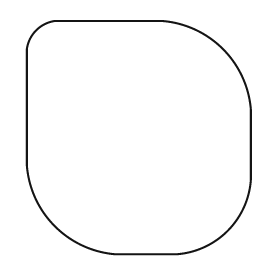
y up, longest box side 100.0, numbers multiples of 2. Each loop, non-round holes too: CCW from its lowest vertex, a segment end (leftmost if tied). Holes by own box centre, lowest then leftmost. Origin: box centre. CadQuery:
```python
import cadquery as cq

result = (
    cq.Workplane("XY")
    .moveTo(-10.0, -50.0)
    .lineTo(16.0, -50.0)
    .threePointArc((38.0, -40.0), (48.0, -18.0))
    .lineTo(48.0, 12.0)
    .threePointArc((36.0, 38.0), (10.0, 50.0))
    .lineTo(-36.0, 50.0)
    .threePointArc((-44.0, 46.0), (-48.0, 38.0))
    .lineTo(-48.0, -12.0)
    .threePointArc((-36.0, -38.0), (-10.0, -50.0))
    .close()
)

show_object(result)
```